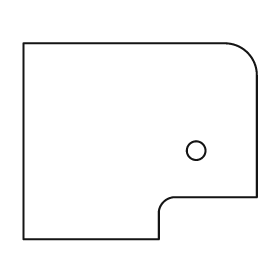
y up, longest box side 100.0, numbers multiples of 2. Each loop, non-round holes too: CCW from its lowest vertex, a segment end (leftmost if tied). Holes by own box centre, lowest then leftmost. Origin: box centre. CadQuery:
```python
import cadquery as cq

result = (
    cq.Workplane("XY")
    .moveTo(-50.0, -42.0)
    .lineTo(8.0, -42.0)
    .lineTo(8.0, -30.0)
    .threePointArc((10.0, -26.0), (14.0, -24.0))
    .lineTo(50.0, -24.0)
    .lineTo(50.0, 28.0)
    .threePointArc((46.0, 38.0), (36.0, 42.0))
    .lineTo(-50.0, 42.0)
    .close()
    .moveTo(24.0, -4.0)
    .circle(4.0)
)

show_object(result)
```